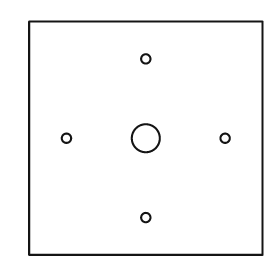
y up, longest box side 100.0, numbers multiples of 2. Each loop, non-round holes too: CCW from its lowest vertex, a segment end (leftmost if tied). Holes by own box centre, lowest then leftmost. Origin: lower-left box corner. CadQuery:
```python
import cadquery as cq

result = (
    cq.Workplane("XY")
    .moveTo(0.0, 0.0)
    .lineTo(100.0, 0.0)
    .lineTo(100.0, 100.0)
    .lineTo(0.0, 100.0)
    .close()
    .moveTo(50.0, 16.0)
    .circle(2.0)
    .moveTo(16.0, 50.0)
    .circle(2.0)
    .moveTo(50.0, 50.0)
    .circle(6.0)
    .moveTo(84.0, 50.0)
    .circle(2.0)
    .moveTo(50.0, 84.0)
    .circle(2.0)
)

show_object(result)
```